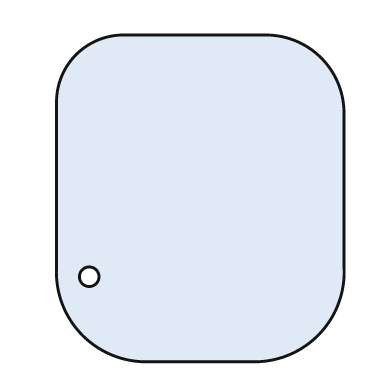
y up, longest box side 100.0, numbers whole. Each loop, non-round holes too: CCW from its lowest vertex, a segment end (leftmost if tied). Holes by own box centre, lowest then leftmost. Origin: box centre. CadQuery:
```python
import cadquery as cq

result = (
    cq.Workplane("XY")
    .moveTo(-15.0, -50.0)
    .lineTo(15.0, -50.0)
    .threePointArc((36.0, -42.0), (44.0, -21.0))
    .lineTo(44.0, 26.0)
    .threePointArc((37.0, 43.0), (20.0, 50.0))
    .lineTo(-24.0, 50.0)
    .threePointArc((-38.0, 44.0), (-44.0, 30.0))
    .lineTo(-44.0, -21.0)
    .threePointArc((-36.0, -42.0), (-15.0, -50.0))
    .close()
    .moveTo(-34.0, -24.0)
    .circle(3.0)
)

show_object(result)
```